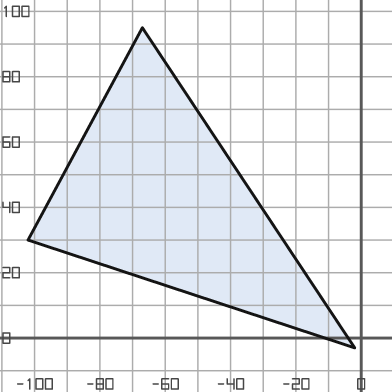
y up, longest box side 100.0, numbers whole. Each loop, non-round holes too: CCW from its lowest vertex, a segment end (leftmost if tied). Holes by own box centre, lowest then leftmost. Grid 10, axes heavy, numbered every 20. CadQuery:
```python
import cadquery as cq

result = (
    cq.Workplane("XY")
    .moveTo(-2.0, -3.0)
    .lineTo(-67.0, 95.0)
    .lineTo(-102.0, 30.0)
    .close()
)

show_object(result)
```